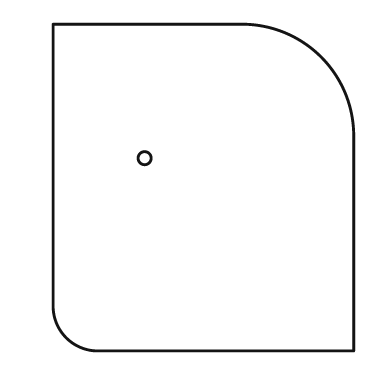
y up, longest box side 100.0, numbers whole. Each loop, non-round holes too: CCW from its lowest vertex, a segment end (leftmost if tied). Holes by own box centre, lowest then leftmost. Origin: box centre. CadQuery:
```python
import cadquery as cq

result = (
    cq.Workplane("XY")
    .moveTo(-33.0, -50.0)
    .lineTo(46.0, -50.0)
    .lineTo(46.0, 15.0)
    .threePointArc((36.0, 40.0), (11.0, 50.0))
    .lineTo(-46.0, 50.0)
    .lineTo(-46.0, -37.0)
    .threePointArc((-42.0, -46.0), (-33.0, -50.0))
    .close()
    .moveTo(-18.0, 9.0)
    .circle(2.0)
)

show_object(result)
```